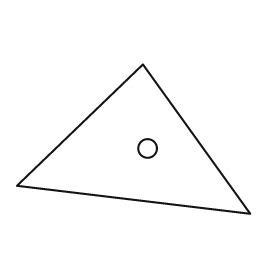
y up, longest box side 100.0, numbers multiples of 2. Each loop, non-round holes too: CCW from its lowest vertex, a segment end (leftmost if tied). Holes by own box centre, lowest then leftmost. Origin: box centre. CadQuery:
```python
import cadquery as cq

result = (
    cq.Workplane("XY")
    .moveTo(50.0, -32.0)
    .lineTo(4.0, 32.0)
    .lineTo(-50.0, -20.0)
    .close()
    .moveTo(6.0, -4.0)
    .circle(4.0)
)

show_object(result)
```